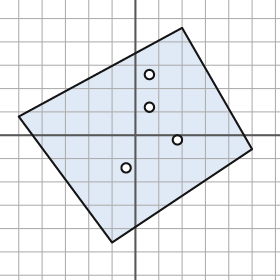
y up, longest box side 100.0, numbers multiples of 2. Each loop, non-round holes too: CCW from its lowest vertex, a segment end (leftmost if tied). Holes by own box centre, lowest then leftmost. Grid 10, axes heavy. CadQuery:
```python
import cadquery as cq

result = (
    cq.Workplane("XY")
    .moveTo(-10.0, -46.0)
    .lineTo(50.0, -6.0)
    .lineTo(20.0, 46.0)
    .lineTo(-50.0, 8.0)
    .close()
    .moveTo(-4.0, -14.0)
    .circle(2.0)
    .moveTo(18.0, -2.0)
    .circle(2.0)
    .moveTo(6.0, 12.0)
    .circle(2.0)
    .moveTo(6.0, 26.0)
    .circle(2.0)
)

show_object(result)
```